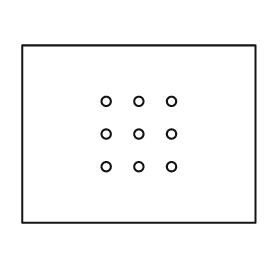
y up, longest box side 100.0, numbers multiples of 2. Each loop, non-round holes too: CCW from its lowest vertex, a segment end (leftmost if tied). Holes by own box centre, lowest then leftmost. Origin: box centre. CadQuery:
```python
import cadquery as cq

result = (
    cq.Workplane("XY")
    .moveTo(-50.0, -38.0)
    .lineTo(50.0, -38.0)
    .lineTo(50.0, 38.0)
    .lineTo(-50.0, 38.0)
    .close()
    .moveTo(-14.0, -14.0)
    .circle(2.0)
    .moveTo(0.0, -14.0)
    .circle(2.0)
    .moveTo(14.0, -14.0)
    .circle(2.0)
    .moveTo(-14.0, 0.0)
    .circle(2.0)
    .moveTo(0.0, 0.0)
    .circle(2.0)
    .moveTo(14.0, 0.0)
    .circle(2.0)
    .moveTo(-14.0, 14.0)
    .circle(2.0)
    .moveTo(0.0, 14.0)
    .circle(2.0)
    .moveTo(14.0, 14.0)
    .circle(2.0)
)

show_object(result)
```